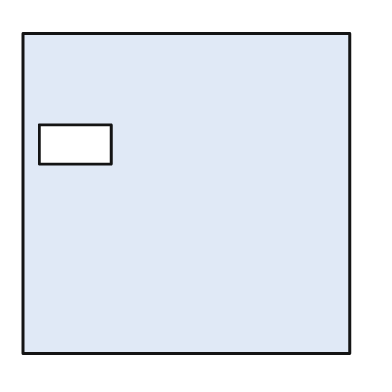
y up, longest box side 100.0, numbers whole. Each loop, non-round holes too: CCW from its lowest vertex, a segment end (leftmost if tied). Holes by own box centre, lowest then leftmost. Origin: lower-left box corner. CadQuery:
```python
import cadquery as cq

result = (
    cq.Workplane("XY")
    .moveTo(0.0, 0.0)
    .lineTo(100.0, 0.0)
    .lineTo(100.0, 98.0)
    .lineTo(0.0, 98.0)
    .close()
    .moveTo(5.0, 58.0)
    .lineTo(27.0, 58.0)
    .lineTo(27.0, 70.0)
    .lineTo(5.0, 70.0)
    .close()
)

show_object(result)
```